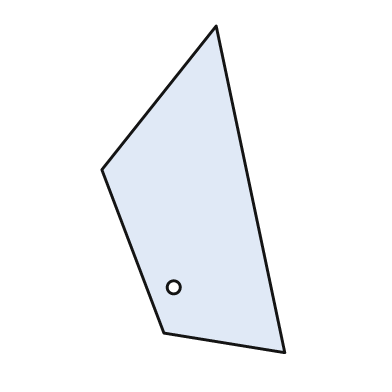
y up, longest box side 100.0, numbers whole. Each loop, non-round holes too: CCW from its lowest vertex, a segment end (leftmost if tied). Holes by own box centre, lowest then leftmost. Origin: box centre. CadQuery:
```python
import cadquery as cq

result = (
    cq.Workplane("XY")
    .moveTo(28.0, -50.0)
    .lineTo(7.0, 50.0)
    .lineTo(-28.0, 6.0)
    .lineTo(-9.0, -44.0)
    .close()
    .moveTo(-6.0, -30.0)
    .circle(2.0)
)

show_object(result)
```